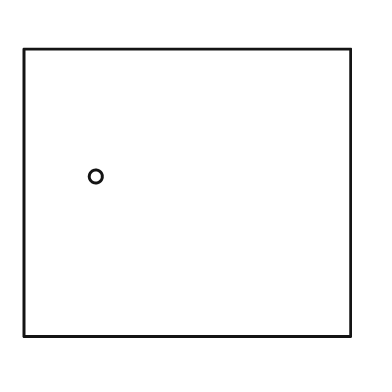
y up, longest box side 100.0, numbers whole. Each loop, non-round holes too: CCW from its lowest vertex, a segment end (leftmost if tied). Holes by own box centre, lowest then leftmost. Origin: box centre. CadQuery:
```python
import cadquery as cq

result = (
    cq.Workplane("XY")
    .moveTo(-50.0, -44.0)
    .lineTo(50.0, -44.0)
    .lineTo(50.0, 44.0)
    .lineTo(-50.0, 44.0)
    .close()
    .moveTo(-28.0, 5.0)
    .circle(2.0)
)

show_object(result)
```